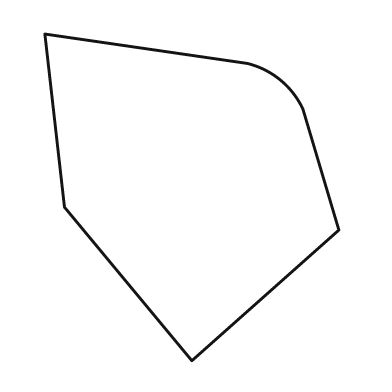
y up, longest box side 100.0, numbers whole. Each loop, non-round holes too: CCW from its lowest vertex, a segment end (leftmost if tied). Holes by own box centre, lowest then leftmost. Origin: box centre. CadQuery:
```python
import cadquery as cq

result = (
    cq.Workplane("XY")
    .moveTo(0.0, -50.0)
    .lineTo(45.0, -10.0)
    .lineTo(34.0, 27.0)
    .threePointArc((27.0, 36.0), (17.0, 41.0))
    .lineTo(-45.0, 50.0)
    .lineTo(-39.0, -3.0)
    .close()
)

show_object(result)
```